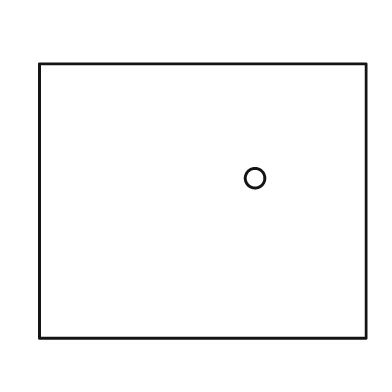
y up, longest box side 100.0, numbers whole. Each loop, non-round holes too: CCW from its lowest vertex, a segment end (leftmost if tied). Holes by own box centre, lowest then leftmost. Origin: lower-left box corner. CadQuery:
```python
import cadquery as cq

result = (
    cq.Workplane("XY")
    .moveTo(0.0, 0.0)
    .lineTo(100.0, 0.0)
    .lineTo(100.0, 84.0)
    .lineTo(0.0, 84.0)
    .close()
    .moveTo(66.0, 49.0)
    .circle(3.0)
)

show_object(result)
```